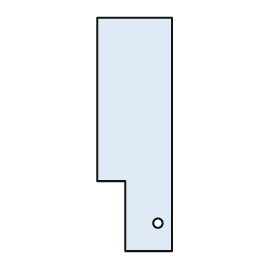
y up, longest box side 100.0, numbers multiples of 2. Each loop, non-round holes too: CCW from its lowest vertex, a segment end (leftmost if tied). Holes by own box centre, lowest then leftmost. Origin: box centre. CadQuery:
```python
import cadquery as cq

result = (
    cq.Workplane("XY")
    .moveTo(-4.0, -50.0)
    .lineTo(16.0, -50.0)
    .lineTo(16.0, 50.0)
    .lineTo(-16.0, 50.0)
    .lineTo(-16.0, -20.0)
    .lineTo(-4.0, -20.0)
    .close()
    .moveTo(10.0, -38.0)
    .circle(2.0)
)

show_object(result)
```